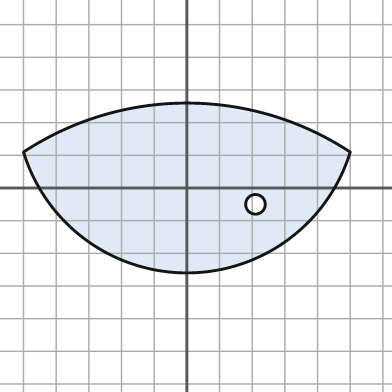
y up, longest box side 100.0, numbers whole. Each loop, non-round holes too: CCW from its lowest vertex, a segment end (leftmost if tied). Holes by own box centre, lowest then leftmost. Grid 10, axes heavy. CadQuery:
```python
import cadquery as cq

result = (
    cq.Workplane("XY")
    .moveTo(-50.0, 11.0)
    .threePointArc((0.0, -26.0), (50.0, 11.0))
    .threePointArc((0.0, 26.0), (-50.0, 11.0))
    .close()
    .moveTo(21.0, -5.0)
    .circle(3.0)
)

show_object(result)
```